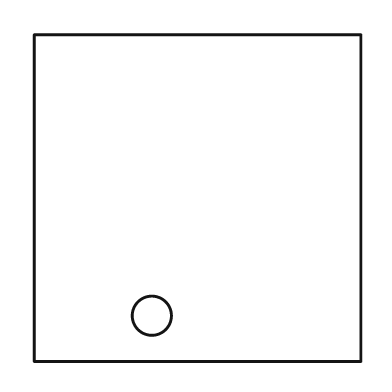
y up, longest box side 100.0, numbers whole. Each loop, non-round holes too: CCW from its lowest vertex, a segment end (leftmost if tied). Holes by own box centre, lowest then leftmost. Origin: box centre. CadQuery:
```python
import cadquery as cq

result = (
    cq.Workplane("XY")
    .moveTo(-50.0, -50.0)
    .lineTo(50.0, -50.0)
    .lineTo(50.0, 50.0)
    .lineTo(-50.0, 50.0)
    .close()
    .moveTo(-14.0, -36.0)
    .circle(6.0)
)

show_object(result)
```